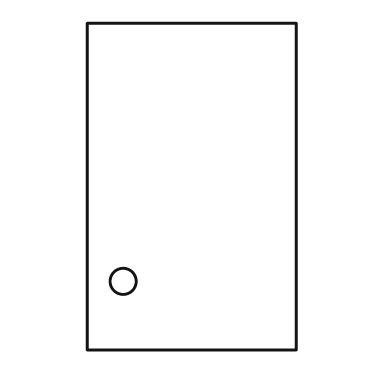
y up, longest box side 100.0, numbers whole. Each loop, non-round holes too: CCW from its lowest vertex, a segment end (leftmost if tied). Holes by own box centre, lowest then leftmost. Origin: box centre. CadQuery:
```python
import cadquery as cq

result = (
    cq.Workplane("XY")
    .moveTo(-32.0, -50.0)
    .lineTo(32.0, -50.0)
    .lineTo(32.0, 50.0)
    .lineTo(-32.0, 50.0)
    .close()
    .moveTo(-21.0, -29.0)
    .circle(4.0)
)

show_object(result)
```